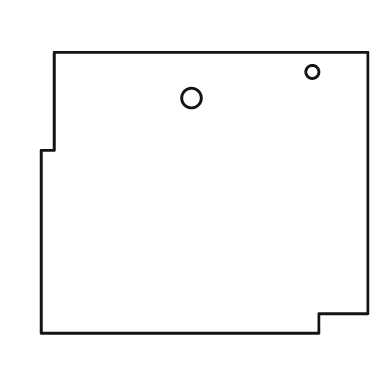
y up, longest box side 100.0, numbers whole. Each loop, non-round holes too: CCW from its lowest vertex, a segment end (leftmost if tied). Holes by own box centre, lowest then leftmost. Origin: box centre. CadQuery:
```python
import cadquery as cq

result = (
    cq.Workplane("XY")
    .moveTo(-50.0, -43.0)
    .lineTo(35.0, -43.0)
    .lineTo(35.0, -37.0)
    .lineTo(50.0, -37.0)
    .lineTo(50.0, 43.0)
    .lineTo(-46.0, 43.0)
    .lineTo(-46.0, 13.0)
    .lineTo(-50.0, 13.0)
    .close()
    .moveTo(-4.0, 29.0)
    .circle(3.0)
    .moveTo(33.0, 37.0)
    .circle(2.0)
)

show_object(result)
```